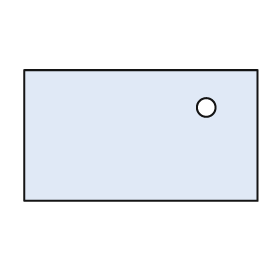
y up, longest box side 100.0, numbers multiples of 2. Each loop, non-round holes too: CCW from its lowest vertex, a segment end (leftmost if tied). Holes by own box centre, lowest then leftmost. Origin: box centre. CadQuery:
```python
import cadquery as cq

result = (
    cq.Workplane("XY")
    .moveTo(-50.0, -28.0)
    .lineTo(50.0, -28.0)
    .lineTo(50.0, 28.0)
    .lineTo(-50.0, 28.0)
    .close()
    .moveTo(28.0, 12.0)
    .circle(4.0)
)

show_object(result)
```